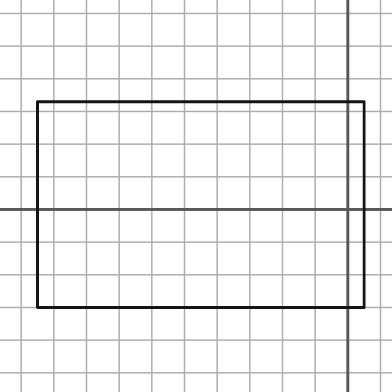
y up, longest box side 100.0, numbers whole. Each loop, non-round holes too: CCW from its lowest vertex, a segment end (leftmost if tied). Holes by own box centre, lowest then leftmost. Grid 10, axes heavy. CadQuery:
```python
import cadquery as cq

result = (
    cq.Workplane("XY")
    .moveTo(-95.0, -30.0)
    .lineTo(5.0, -30.0)
    .lineTo(5.0, 33.0)
    .lineTo(-95.0, 33.0)
    .close()
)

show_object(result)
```